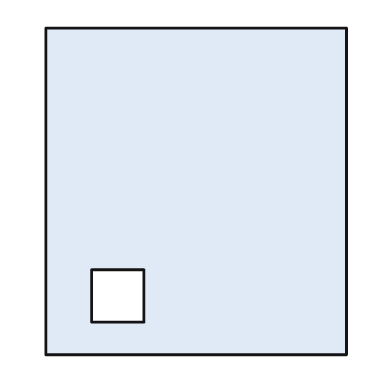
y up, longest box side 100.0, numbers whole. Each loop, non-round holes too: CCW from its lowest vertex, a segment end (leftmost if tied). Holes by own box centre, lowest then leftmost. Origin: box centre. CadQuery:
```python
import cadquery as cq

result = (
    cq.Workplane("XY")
    .moveTo(-46.0, -50.0)
    .lineTo(46.0, -50.0)
    .lineTo(46.0, 50.0)
    .lineTo(-46.0, 50.0)
    .close()
    .moveTo(-32.0, -40.0)
    .lineTo(-16.0, -40.0)
    .lineTo(-16.0, -24.0)
    .lineTo(-32.0, -24.0)
    .close()
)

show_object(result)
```